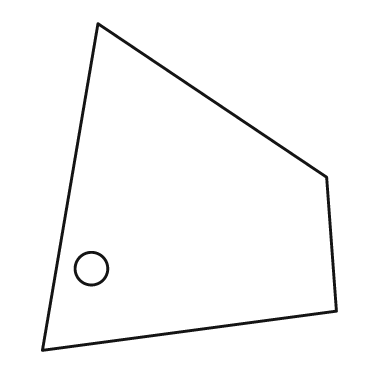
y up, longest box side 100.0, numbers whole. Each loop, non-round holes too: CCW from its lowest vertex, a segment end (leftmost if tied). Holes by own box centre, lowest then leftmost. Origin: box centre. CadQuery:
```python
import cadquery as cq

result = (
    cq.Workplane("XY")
    .moveTo(-45.0, -50.0)
    .lineTo(45.0, -38.0)
    .lineTo(42.0, 3.0)
    .lineTo(-28.0, 50.0)
    .close()
    .moveTo(-30.0, -25.0)
    .circle(5.0)
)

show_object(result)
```